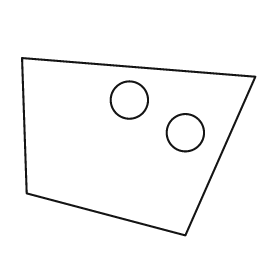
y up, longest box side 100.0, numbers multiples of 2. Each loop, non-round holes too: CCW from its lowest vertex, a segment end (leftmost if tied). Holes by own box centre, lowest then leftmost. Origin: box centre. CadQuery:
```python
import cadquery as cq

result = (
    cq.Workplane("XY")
    .moveTo(20.0, -38.0)
    .lineTo(50.0, 30.0)
    .lineTo(-50.0, 38.0)
    .lineTo(-48.0, -20.0)
    .close()
    .moveTo(20.0, 6.0)
    .circle(8.0)
    .moveTo(-4.0, 20.0)
    .circle(8.0)
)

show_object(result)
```